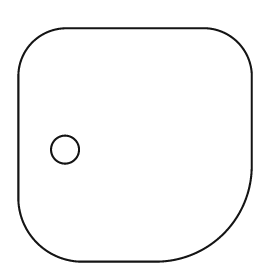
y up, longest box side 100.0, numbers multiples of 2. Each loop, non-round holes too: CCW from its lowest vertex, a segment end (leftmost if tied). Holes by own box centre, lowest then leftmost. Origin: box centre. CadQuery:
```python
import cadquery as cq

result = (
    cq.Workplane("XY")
    .moveTo(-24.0, -50.0)
    .lineTo(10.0, -50.0)
    .threePointArc((38.0, -38.0), (50.0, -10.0))
    .lineTo(50.0, 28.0)
    .threePointArc((44.0, 44.0), (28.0, 50.0))
    .lineTo(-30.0, 50.0)
    .threePointArc((-44.0, 44.0), (-50.0, 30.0))
    .lineTo(-50.0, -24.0)
    .threePointArc((-42.0, -42.0), (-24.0, -50.0))
    .close()
    .moveTo(-30.0, -2.0)
    .circle(6.0)
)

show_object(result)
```